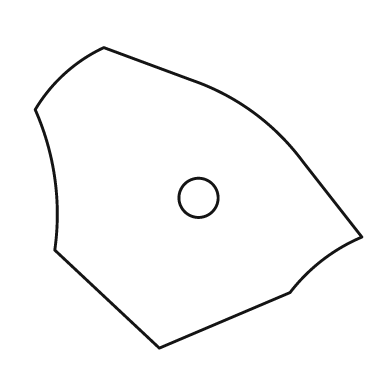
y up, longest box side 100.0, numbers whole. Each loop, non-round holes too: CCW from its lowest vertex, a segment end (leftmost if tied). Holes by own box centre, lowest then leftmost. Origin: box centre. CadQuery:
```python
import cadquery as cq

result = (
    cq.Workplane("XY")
    .moveTo(-12.0, -46.0)
    .lineTo(28.0, -29.0)
    .threePointArc((38.0, -19.0), (50.0, -12.0))
    .lineTo(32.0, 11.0)
    .threePointArc((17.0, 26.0), (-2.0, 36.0))
    .lineTo(-29.0, 46.0)
    .threePointArc((-41.0, 38.0), (-50.0, 27.0))
    .threePointArc((-44.0, 6.0), (-44.0, -16.0))
    .close()
    .moveTo(0.0, 0.0)
    .circle(6.0)
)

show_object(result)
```